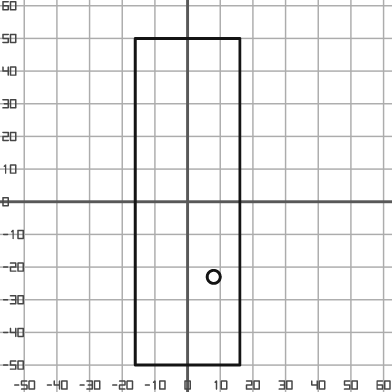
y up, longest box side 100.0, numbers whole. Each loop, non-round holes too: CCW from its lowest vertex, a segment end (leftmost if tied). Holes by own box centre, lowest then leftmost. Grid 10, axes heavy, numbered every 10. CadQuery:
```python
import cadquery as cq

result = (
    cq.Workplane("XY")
    .moveTo(-16.0, -50.0)
    .lineTo(16.0, -50.0)
    .lineTo(16.0, 50.0)
    .lineTo(-16.0, 50.0)
    .close()
    .moveTo(8.0, -23.0)
    .circle(2.0)
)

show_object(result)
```